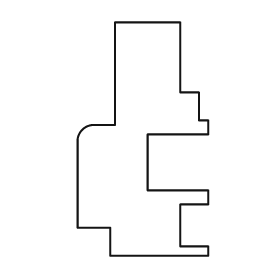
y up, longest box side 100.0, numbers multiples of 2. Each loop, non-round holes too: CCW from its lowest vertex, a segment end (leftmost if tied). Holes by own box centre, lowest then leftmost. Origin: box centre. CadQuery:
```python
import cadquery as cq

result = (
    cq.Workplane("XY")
    .moveTo(-14.0, -50.0)
    .lineTo(28.0, -50.0)
    .lineTo(28.0, -46.0)
    .lineTo(16.0, -46.0)
    .lineTo(16.0, -28.0)
    .lineTo(28.0, -28.0)
    .lineTo(28.0, -22.0)
    .lineTo(2.0, -22.0)
    .lineTo(2.0, 2.0)
    .lineTo(28.0, 2.0)
    .lineTo(28.0, 8.0)
    .lineTo(24.0, 8.0)
    .lineTo(24.0, 20.0)
    .lineTo(16.0, 20.0)
    .lineTo(16.0, 50.0)
    .lineTo(-12.0, 50.0)
    .lineTo(-12.0, 6.0)
    .lineTo(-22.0, 6.0)
    .threePointArc((-26.0, 4.0), (-28.0, 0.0))
    .lineTo(-28.0, -38.0)
    .lineTo(-14.0, -38.0)
    .close()
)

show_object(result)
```